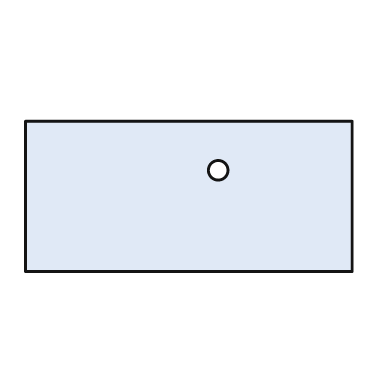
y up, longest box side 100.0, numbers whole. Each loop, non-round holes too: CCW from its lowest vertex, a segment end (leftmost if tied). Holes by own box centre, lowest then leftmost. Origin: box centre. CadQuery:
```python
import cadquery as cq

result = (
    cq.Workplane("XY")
    .moveTo(-50.0, -23.0)
    .lineTo(50.0, -23.0)
    .lineTo(50.0, 23.0)
    .lineTo(-50.0, 23.0)
    .close()
    .moveTo(9.0, 8.0)
    .circle(3.0)
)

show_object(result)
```